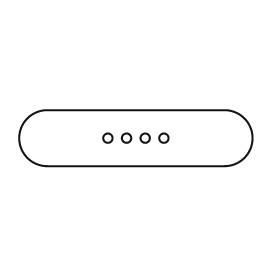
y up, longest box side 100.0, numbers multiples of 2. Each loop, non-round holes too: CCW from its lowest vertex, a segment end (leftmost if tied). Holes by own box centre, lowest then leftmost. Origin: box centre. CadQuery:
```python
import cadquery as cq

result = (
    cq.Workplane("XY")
    .moveTo(-38.0, -12.0)
    .lineTo(38.0, -12.0)
    .threePointArc((50.0, 0.0), (38.0, 12.0))
    .lineTo(-38.0, 12.0)
    .threePointArc((-50.0, 0.0), (-38.0, -12.0))
    .close()
    .moveTo(-12.0, 0.0)
    .circle(2.0)
    .moveTo(-4.0, 0.0)
    .circle(2.0)
    .moveTo(4.0, 0.0)
    .circle(2.0)
    .moveTo(12.0, 0.0)
    .circle(2.0)
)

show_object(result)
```